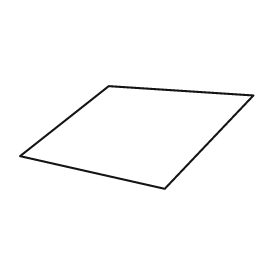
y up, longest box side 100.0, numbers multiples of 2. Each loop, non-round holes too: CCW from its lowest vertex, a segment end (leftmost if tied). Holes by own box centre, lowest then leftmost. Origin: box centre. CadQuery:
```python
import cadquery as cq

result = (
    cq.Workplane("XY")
    .moveTo(12.0, -22.0)
    .lineTo(50.0, 18.0)
    .lineTo(-12.0, 22.0)
    .lineTo(-50.0, -8.0)
    .close()
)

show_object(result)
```